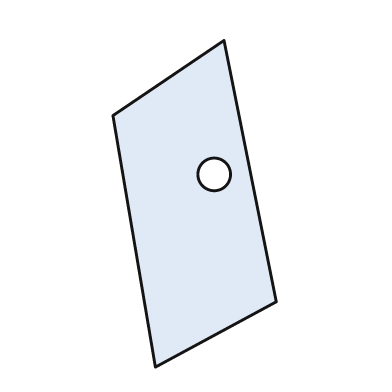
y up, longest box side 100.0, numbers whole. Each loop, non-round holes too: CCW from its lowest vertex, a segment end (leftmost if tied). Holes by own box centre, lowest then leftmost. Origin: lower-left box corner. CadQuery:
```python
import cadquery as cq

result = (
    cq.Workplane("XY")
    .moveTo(13.0, 0.0)
    .lineTo(50.0, 20.0)
    .lineTo(34.0, 100.0)
    .lineTo(0.0, 77.0)
    .close()
    .moveTo(31.0, 59.0)
    .circle(5.0)
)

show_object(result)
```